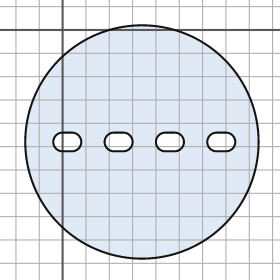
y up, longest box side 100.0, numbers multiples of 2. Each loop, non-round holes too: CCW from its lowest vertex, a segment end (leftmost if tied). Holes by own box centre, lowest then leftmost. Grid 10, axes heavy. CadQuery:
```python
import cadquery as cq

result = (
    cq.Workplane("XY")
    .moveTo(34.0, -48.0)
    .circle(50.0)
    .moveTo(0.0, -52.0)
    .lineTo(4.0, -52.0)
    .threePointArc((8.0, -48.0), (4.0, -44.0))
    .lineTo(0.0, -44.0)
    .threePointArc((-4.0, -48.0), (0.0, -52.0))
    .close()
    .moveTo(22.0, -52.0)
    .lineTo(26.0, -52.0)
    .threePointArc((30.0, -48.0), (26.0, -44.0))
    .lineTo(22.0, -44.0)
    .threePointArc((18.0, -48.0), (22.0, -52.0))
    .close()
    .moveTo(44.0, -52.0)
    .lineTo(48.0, -52.0)
    .threePointArc((52.0, -48.0), (48.0, -44.0))
    .lineTo(44.0, -44.0)
    .threePointArc((40.0, -48.0), (44.0, -52.0))
    .close()
    .moveTo(66.0, -52.0)
    .lineTo(70.0, -52.0)
    .threePointArc((74.0, -48.0), (70.0, -44.0))
    .lineTo(66.0, -44.0)
    .threePointArc((62.0, -48.0), (66.0, -52.0))
    .close()
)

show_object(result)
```